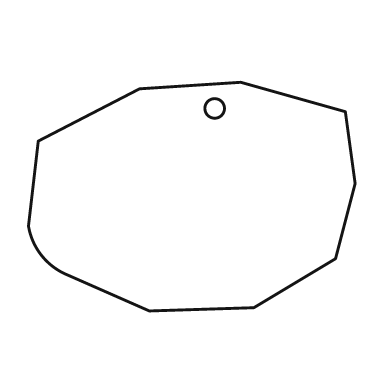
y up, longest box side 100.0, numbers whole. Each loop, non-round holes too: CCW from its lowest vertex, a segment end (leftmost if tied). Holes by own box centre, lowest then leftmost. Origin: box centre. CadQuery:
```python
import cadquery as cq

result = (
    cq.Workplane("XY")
    .moveTo(-13.0, -35.0)
    .lineTo(19.0, -34.0)
    .lineTo(44.0, -19.0)
    .lineTo(50.0, 4.0)
    .lineTo(47.0, 26.0)
    .lineTo(15.0, 35.0)
    .lineTo(-16.0, 33.0)
    .lineTo(-47.0, 17.0)
    .lineTo(-50.0, -9.0)
    .threePointArc((-46.0, -18.0), (-38.0, -24.0))
    .close()
    .moveTo(7.0, 27.0)
    .circle(3.0)
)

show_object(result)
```